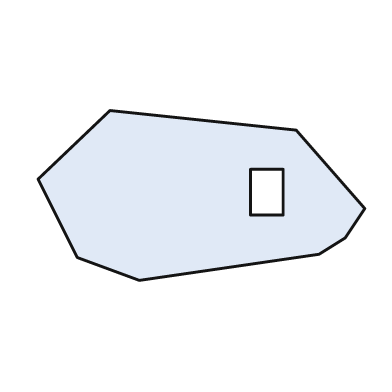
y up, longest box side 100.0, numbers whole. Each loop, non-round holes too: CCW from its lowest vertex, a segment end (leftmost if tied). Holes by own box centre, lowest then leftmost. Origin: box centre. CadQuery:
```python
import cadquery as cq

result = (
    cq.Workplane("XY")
    .moveTo(-19.0, -26.0)
    .lineTo(36.0, -18.0)
    .lineTo(44.0, -13.0)
    .lineTo(50.0, -4.0)
    .lineTo(29.0, 20.0)
    .lineTo(-28.0, 26.0)
    .lineTo(-50.0, 5.0)
    .lineTo(-38.0, -19.0)
    .close()
    .moveTo(15.0, -6.0)
    .lineTo(25.0, -6.0)
    .lineTo(25.0, 8.0)
    .lineTo(15.0, 8.0)
    .close()
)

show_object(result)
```